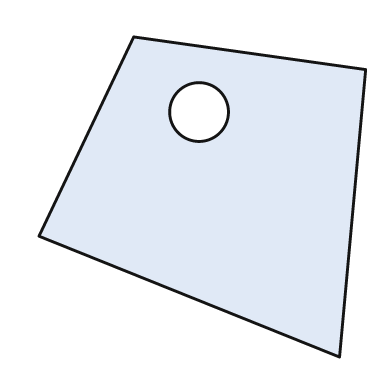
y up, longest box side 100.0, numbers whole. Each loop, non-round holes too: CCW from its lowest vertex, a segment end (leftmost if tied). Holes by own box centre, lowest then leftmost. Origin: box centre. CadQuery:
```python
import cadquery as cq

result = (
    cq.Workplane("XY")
    .moveTo(42.0, -49.0)
    .lineTo(50.0, 39.0)
    .lineTo(-21.0, 49.0)
    .lineTo(-50.0, -12.0)
    .close()
    .moveTo(-1.0, 26.0)
    .circle(9.0)
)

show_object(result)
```